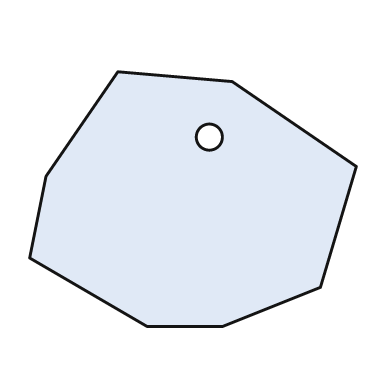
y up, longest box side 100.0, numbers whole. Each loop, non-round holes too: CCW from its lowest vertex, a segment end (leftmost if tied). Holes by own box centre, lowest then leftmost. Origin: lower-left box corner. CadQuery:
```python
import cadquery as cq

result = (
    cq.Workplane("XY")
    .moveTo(36.0, 0.0)
    .lineTo(59.0, 0.0)
    .lineTo(89.0, 12.0)
    .lineTo(100.0, 49.0)
    .lineTo(62.0, 75.0)
    .lineTo(27.0, 78.0)
    .lineTo(5.0, 46.0)
    .lineTo(0.0, 21.0)
    .close()
    .moveTo(55.0, 58.0)
    .circle(4.0)
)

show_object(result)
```